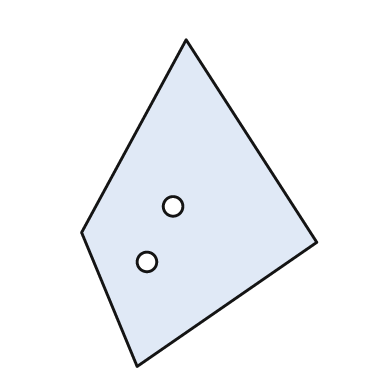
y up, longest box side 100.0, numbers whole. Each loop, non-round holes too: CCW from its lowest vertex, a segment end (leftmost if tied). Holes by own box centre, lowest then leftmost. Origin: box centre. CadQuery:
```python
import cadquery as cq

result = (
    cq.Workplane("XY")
    .moveTo(-19.0, -50.0)
    .lineTo(36.0, -12.0)
    .lineTo(-4.0, 50.0)
    .lineTo(-36.0, -9.0)
    .close()
    .moveTo(-16.0, -18.0)
    .circle(3.0)
    .moveTo(-8.0, -1.0)
    .circle(3.0)
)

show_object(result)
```